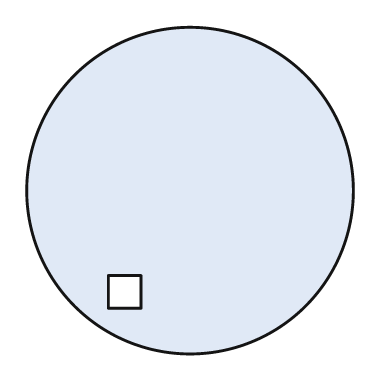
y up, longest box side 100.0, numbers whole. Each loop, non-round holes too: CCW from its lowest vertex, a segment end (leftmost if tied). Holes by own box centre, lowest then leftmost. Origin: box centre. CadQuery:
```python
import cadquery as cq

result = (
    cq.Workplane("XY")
    .moveTo(0.0, 0.0)
    .circle(50.0)
    .moveTo(-25.0, -36.0)
    .lineTo(-15.0, -36.0)
    .lineTo(-15.0, -26.0)
    .lineTo(-25.0, -26.0)
    .close()
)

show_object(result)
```